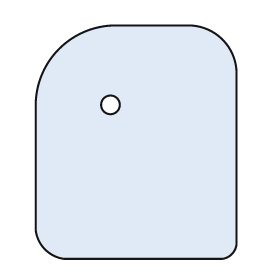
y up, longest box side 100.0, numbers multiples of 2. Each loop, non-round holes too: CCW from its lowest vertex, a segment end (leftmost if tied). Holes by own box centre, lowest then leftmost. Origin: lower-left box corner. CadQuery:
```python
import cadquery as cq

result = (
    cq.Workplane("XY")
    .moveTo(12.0, 0.0)
    .lineTo(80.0, 0.0)
    .threePointArc((84.0, 2.0), (86.0, 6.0))
    .lineTo(86.0, 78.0)
    .threePointArc((80.0, 94.0), (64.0, 100.0))
    .lineTo(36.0, 100.0)
    .threePointArc((10.0, 90.0), (0.0, 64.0))
    .lineTo(0.0, 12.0)
    .threePointArc((4.0, 4.0), (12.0, 0.0))
    .close()
    .moveTo(32.0, 66.0)
    .circle(4.0)
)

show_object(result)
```